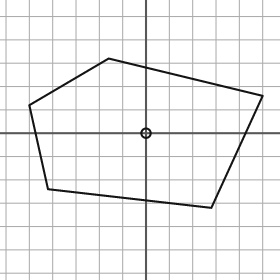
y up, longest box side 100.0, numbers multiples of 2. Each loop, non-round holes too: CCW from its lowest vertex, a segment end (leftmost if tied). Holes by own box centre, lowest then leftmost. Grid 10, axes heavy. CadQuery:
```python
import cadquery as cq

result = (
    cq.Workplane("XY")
    .moveTo(28.0, -32.0)
    .lineTo(50.0, 16.0)
    .lineTo(-16.0, 32.0)
    .lineTo(-50.0, 12.0)
    .lineTo(-42.0, -24.0)
    .close()
    .moveTo(0.0, 0.0)
    .circle(2.0)
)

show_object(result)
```